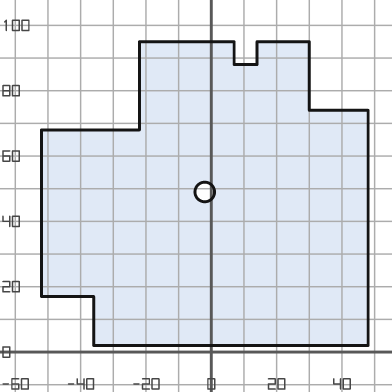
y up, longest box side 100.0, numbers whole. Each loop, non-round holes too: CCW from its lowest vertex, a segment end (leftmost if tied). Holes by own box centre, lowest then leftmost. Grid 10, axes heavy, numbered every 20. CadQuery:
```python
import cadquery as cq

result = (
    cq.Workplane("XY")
    .moveTo(-36.0, 2.0)
    .lineTo(48.0, 2.0)
    .lineTo(48.0, 74.0)
    .lineTo(30.0, 74.0)
    .lineTo(30.0, 95.0)
    .lineTo(14.0, 95.0)
    .lineTo(14.0, 88.0)
    .lineTo(7.0, 88.0)
    .lineTo(7.0, 95.0)
    .lineTo(-22.0, 95.0)
    .lineTo(-22.0, 68.0)
    .lineTo(-52.0, 68.0)
    .lineTo(-52.0, 17.0)
    .lineTo(-36.0, 17.0)
    .close()
    .moveTo(-2.0, 49.0)
    .circle(3.0)
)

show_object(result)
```